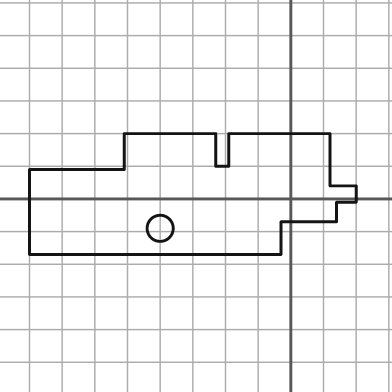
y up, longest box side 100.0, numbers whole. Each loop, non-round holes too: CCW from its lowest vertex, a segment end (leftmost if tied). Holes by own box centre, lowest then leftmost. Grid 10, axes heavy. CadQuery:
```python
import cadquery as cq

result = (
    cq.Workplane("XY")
    .moveTo(-80.0, -17.0)
    .lineTo(-3.0, -17.0)
    .lineTo(-3.0, -7.0)
    .lineTo(14.0, -7.0)
    .lineTo(14.0, -1.0)
    .lineTo(20.0, -1.0)
    .lineTo(20.0, 4.0)
    .lineTo(12.0, 4.0)
    .lineTo(12.0, 20.0)
    .lineTo(-19.0, 20.0)
    .lineTo(-19.0, 10.0)
    .lineTo(-23.0, 10.0)
    .lineTo(-23.0, 20.0)
    .lineTo(-51.0, 20.0)
    .lineTo(-51.0, 9.0)
    .lineTo(-80.0, 9.0)
    .close()
    .moveTo(-40.0, -9.0)
    .circle(4.0)
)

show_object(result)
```